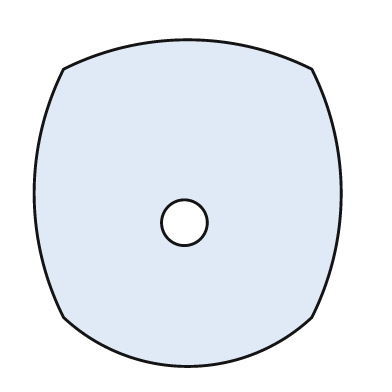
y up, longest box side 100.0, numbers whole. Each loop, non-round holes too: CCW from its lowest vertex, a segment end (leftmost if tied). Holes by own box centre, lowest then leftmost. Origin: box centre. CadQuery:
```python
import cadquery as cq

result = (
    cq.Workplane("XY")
    .moveTo(-38.0, -35.0)
    .threePointArc((0.0, -50.0), (38.0, -35.0))
    .threePointArc((47.0, 3.0), (38.0, 41.0))
    .threePointArc((0.0, 50.0), (-38.0, 41.0))
    .threePointArc((-47.0, 3.0), (-38.0, -35.0))
    .close()
    .moveTo(-1.0, -6.0)
    .circle(7.0)
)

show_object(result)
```